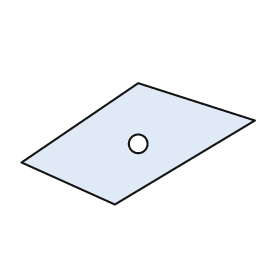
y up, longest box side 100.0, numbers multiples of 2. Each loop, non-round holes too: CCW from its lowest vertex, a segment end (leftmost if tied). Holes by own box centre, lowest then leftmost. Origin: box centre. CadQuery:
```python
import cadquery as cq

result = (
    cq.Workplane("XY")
    .moveTo(-10.0, -26.0)
    .lineTo(50.0, 10.0)
    .lineTo(0.0, 26.0)
    .lineTo(-50.0, -8.0)
    .close()
    .moveTo(0.0, 0.0)
    .circle(4.0)
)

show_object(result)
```